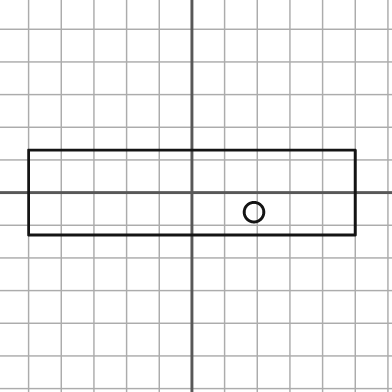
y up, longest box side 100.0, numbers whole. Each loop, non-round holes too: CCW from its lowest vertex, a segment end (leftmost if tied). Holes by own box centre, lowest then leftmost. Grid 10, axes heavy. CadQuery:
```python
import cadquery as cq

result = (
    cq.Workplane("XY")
    .moveTo(-50.0, -13.0)
    .lineTo(50.0, -13.0)
    .lineTo(50.0, 13.0)
    .lineTo(-50.0, 13.0)
    .close()
    .moveTo(19.0, -6.0)
    .circle(3.0)
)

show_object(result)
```